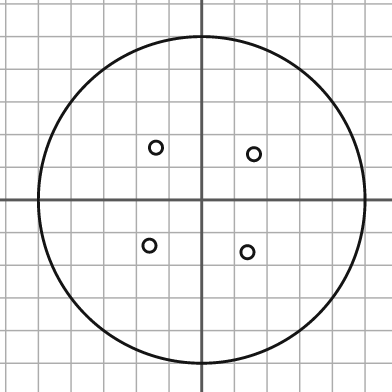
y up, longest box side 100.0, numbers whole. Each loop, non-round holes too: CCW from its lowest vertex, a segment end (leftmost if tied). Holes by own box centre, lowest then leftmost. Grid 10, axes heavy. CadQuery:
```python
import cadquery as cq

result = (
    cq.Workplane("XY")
    .moveTo(0.0, 0.0)
    .circle(50.0)
    .moveTo(14.0, -16.0)
    .circle(2.0)
    .moveTo(-16.0, -14.0)
    .circle(2.0)
    .moveTo(16.0, 14.0)
    .circle(2.0)
    .moveTo(-14.0, 16.0)
    .circle(2.0)
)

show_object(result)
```